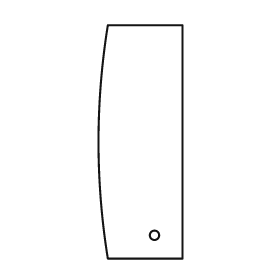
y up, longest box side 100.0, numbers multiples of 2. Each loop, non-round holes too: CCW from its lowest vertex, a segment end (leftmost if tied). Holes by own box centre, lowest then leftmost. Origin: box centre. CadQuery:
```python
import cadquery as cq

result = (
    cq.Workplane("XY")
    .moveTo(-14.0, -50.0)
    .lineTo(18.0, -50.0)
    .lineTo(18.0, 50.0)
    .lineTo(-14.0, 50.0)
    .threePointArc((-18.0, 0.0), (-14.0, -50.0))
    .close()
    .moveTo(6.0, -40.0)
    .circle(2.0)
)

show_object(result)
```